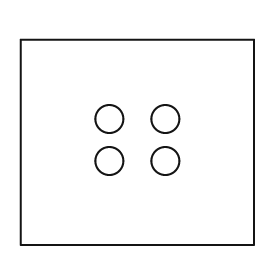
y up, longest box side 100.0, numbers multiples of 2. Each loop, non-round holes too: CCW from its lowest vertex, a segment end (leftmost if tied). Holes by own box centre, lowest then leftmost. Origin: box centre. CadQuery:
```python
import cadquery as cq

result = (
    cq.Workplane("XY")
    .moveTo(-50.0, -44.0)
    .lineTo(50.0, -44.0)
    .lineTo(50.0, 44.0)
    .lineTo(-50.0, 44.0)
    .close()
    .moveTo(-12.0, -8.0)
    .circle(6.0)
    .moveTo(12.0, -8.0)
    .circle(6.0)
    .moveTo(-12.0, 10.0)
    .circle(6.0)
    .moveTo(12.0, 10.0)
    .circle(6.0)
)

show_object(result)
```